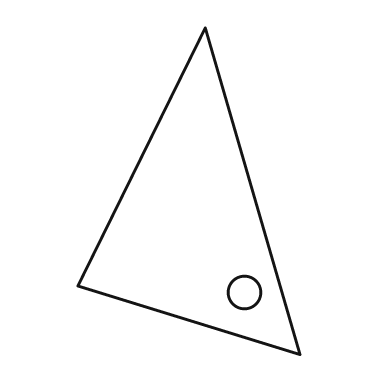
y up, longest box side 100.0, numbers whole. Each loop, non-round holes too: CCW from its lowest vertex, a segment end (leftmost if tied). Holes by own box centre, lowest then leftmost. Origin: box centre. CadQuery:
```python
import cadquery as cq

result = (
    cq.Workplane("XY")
    .moveTo(34.0, -50.0)
    .lineTo(5.0, 50.0)
    .lineTo(-34.0, -29.0)
    .close()
    .moveTo(17.0, -31.0)
    .circle(5.0)
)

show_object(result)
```